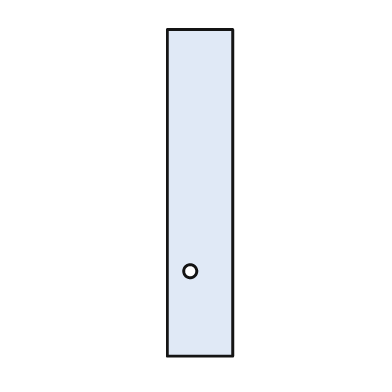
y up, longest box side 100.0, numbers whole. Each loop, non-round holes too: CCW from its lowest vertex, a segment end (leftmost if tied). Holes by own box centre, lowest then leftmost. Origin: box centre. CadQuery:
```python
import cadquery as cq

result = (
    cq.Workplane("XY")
    .moveTo(-10.0, -50.0)
    .lineTo(10.0, -50.0)
    .lineTo(10.0, 50.0)
    .lineTo(-10.0, 50.0)
    .close()
    .moveTo(-3.0, -24.0)
    .circle(2.0)
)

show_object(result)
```